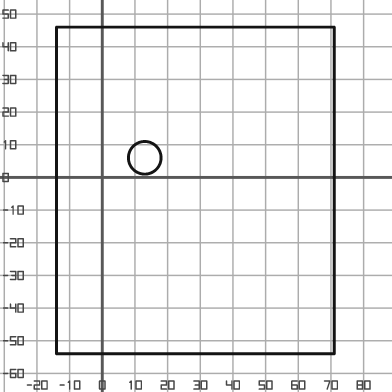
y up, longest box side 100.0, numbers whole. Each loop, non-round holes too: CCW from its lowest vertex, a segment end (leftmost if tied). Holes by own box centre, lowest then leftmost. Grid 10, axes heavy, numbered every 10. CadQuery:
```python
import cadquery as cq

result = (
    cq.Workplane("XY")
    .moveTo(-14.0, -54.0)
    .lineTo(71.0, -54.0)
    .lineTo(71.0, 46.0)
    .lineTo(-14.0, 46.0)
    .close()
    .moveTo(13.0, 6.0)
    .circle(5.0)
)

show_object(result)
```